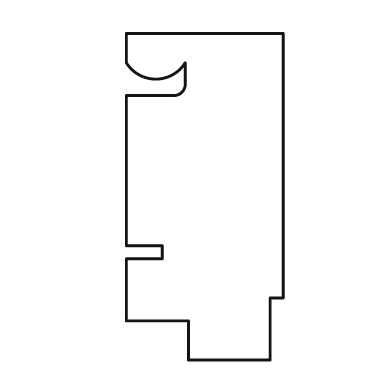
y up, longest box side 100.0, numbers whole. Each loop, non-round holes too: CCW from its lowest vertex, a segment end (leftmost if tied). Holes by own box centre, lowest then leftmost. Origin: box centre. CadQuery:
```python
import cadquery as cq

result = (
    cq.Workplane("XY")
    .moveTo(-5.0, -50.0)
    .lineTo(20.0, -50.0)
    .lineTo(20.0, -31.0)
    .lineTo(24.0, -31.0)
    .lineTo(24.0, 50.0)
    .lineTo(-24.0, 50.0)
    .lineTo(-24.0, 41.0)
    .threePointArc((-15.0, 36.0), (-6.0, 41.0))
    .lineTo(-6.0, 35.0)
    .threePointArc((-7.0, 32.0), (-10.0, 31.0))
    .lineTo(-24.0, 31.0)
    .lineTo(-24.0, -15.0)
    .lineTo(-13.0, -15.0)
    .lineTo(-13.0, -19.0)
    .lineTo(-24.0, -19.0)
    .lineTo(-24.0, -38.0)
    .lineTo(-5.0, -38.0)
    .close()
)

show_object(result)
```